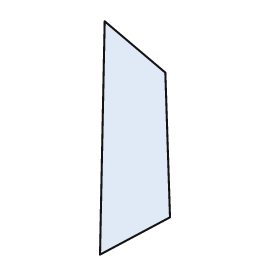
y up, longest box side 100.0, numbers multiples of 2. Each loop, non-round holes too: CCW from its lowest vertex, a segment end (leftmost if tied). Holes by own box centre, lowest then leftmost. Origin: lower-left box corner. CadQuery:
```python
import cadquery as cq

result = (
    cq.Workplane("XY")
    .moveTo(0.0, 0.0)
    .lineTo(30.0, 16.0)
    .lineTo(28.0, 78.0)
    .lineTo(2.0, 100.0)
    .close()
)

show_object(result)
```